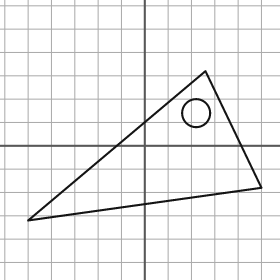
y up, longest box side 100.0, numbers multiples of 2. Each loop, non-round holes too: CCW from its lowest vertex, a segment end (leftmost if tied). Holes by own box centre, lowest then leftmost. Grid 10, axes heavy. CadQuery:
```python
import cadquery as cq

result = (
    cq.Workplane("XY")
    .moveTo(-50.0, -32.0)
    .lineTo(50.0, -18.0)
    .lineTo(26.0, 32.0)
    .close()
    .moveTo(22.0, 14.0)
    .circle(6.0)
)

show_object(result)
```